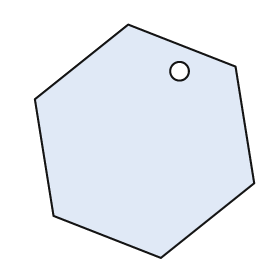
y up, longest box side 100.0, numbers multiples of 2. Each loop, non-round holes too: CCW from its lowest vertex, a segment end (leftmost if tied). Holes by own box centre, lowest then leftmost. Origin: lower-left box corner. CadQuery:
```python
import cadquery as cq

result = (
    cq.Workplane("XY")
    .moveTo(54.0, 0.0)
    .lineTo(94.0, 32.0)
    .lineTo(86.0, 82.0)
    .lineTo(40.0, 100.0)
    .lineTo(0.0, 68.0)
    .lineTo(8.0, 18.0)
    .close()
    .moveTo(62.0, 80.0)
    .circle(4.0)
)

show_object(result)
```